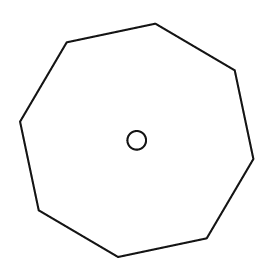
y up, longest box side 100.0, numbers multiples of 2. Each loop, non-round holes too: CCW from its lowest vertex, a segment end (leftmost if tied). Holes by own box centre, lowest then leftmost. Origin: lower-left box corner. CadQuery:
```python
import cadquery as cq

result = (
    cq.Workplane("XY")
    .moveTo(42.0, 0.0)
    .lineTo(80.0, 8.0)
    .lineTo(100.0, 42.0)
    .lineTo(92.0, 80.0)
    .lineTo(58.0, 100.0)
    .lineTo(20.0, 92.0)
    .lineTo(0.0, 58.0)
    .lineTo(8.0, 20.0)
    .close()
    .moveTo(50.0, 50.0)
    .circle(4.0)
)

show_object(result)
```